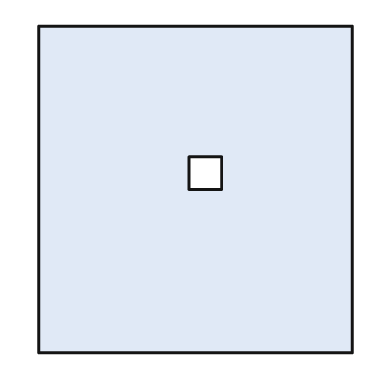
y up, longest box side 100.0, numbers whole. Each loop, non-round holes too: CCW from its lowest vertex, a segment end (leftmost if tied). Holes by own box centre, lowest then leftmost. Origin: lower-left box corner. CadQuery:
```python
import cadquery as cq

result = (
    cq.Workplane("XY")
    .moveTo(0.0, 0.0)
    .lineTo(96.0, 0.0)
    .lineTo(96.0, 100.0)
    .lineTo(0.0, 100.0)
    .close()
    .moveTo(46.0, 50.0)
    .lineTo(56.0, 50.0)
    .lineTo(56.0, 60.0)
    .lineTo(46.0, 60.0)
    .close()
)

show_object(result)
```